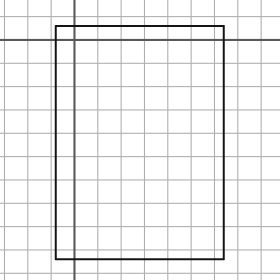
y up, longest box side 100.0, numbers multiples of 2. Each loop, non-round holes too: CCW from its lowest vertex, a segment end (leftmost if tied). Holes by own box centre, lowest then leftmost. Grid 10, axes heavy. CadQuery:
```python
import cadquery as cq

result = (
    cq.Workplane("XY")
    .moveTo(-8.0, -94.0)
    .lineTo(64.0, -94.0)
    .lineTo(64.0, 6.0)
    .lineTo(-8.0, 6.0)
    .close()
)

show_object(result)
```